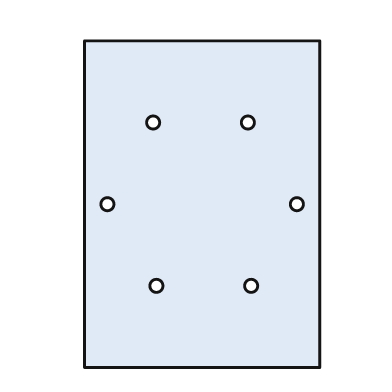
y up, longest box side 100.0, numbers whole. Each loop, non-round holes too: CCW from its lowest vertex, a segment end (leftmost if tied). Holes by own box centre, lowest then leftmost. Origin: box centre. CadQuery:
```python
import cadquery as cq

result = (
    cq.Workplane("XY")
    .moveTo(-36.0, -50.0)
    .lineTo(36.0, -50.0)
    .lineTo(36.0, 50.0)
    .lineTo(-36.0, 50.0)
    .close()
    .moveTo(-14.0, -25.0)
    .circle(2.0)
    .moveTo(15.0, -25.0)
    .circle(2.0)
    .moveTo(-29.0, 0.0)
    .circle(2.0)
    .moveTo(29.0, 0.0)
    .circle(2.0)
    .moveTo(-15.0, 25.0)
    .circle(2.0)
    .moveTo(14.0, 25.0)
    .circle(2.0)
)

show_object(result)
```